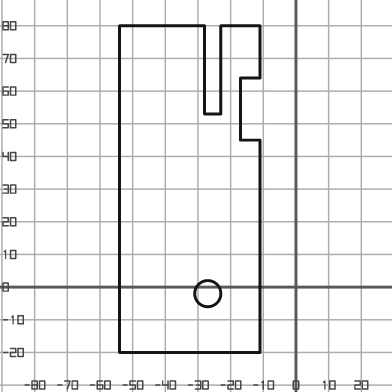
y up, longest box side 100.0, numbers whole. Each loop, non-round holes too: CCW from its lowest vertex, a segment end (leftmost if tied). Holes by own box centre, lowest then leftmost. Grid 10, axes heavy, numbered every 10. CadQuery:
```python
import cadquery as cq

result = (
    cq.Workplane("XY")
    .moveTo(-54.0, -20.0)
    .lineTo(-11.0, -20.0)
    .lineTo(-11.0, 45.0)
    .lineTo(-17.0, 45.0)
    .lineTo(-17.0, 64.0)
    .lineTo(-11.0, 64.0)
    .lineTo(-11.0, 80.0)
    .lineTo(-23.0, 80.0)
    .lineTo(-23.0, 53.0)
    .lineTo(-28.0, 53.0)
    .lineTo(-28.0, 80.0)
    .lineTo(-54.0, 80.0)
    .close()
    .moveTo(-27.0, -2.0)
    .circle(4.0)
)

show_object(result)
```